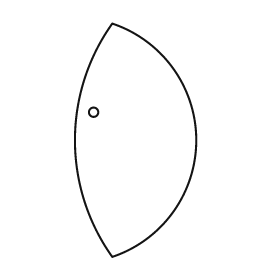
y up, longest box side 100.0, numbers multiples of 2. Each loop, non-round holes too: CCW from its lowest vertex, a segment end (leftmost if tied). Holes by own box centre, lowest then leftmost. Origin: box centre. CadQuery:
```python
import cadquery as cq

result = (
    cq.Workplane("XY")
    .moveTo(-10.0, -50.0)
    .threePointArc((26.0, 0.0), (-10.0, 50.0))
    .threePointArc((-26.0, 0.0), (-10.0, -50.0))
    .close()
    .moveTo(-18.0, 12.0)
    .circle(2.0)
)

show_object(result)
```